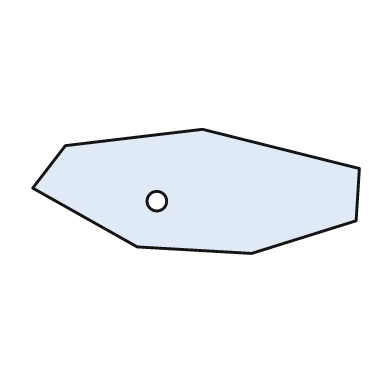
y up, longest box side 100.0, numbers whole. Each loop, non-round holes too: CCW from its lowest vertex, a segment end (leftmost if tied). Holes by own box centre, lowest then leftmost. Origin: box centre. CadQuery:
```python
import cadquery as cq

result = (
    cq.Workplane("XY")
    .moveTo(17.0, -19.0)
    .lineTo(49.0, -9.0)
    .lineTo(50.0, 7.0)
    .lineTo(2.0, 19.0)
    .lineTo(-40.0, 14.0)
    .lineTo(-50.0, 1.0)
    .lineTo(-18.0, -17.0)
    .close()
    .moveTo(-12.0, -3.0)
    .circle(3.0)
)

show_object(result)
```